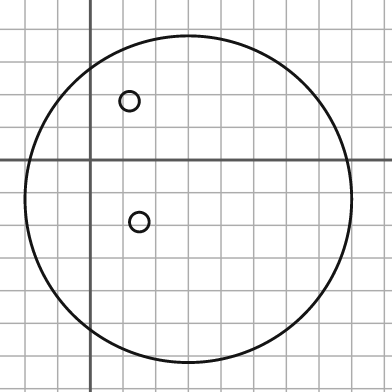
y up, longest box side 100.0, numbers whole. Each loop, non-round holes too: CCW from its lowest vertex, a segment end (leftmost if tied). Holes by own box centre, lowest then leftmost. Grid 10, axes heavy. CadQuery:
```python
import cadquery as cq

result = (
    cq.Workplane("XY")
    .moveTo(30.0, -12.0)
    .circle(50.0)
    .moveTo(15.0, -19.0)
    .circle(3.0)
    .moveTo(12.0, 18.0)
    .circle(3.0)
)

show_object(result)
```